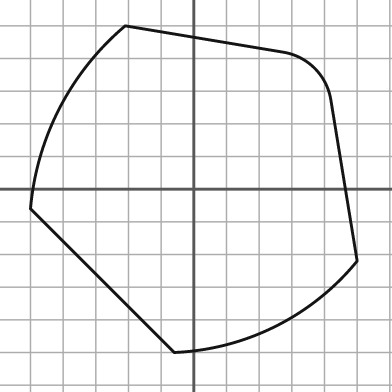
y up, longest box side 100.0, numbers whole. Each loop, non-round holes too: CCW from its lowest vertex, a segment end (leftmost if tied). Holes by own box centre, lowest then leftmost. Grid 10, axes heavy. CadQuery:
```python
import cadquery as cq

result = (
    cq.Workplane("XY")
    .moveTo(-6.0, -50.0)
    .threePointArc((25.0, -42.0), (50.0, -22.0))
    .lineTo(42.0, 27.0)
    .threePointArc((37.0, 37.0), (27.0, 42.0))
    .lineTo(-21.0, 50.0)
    .threePointArc((-41.0, 25.0), (-50.0, -6.0))
    .close()
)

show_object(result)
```